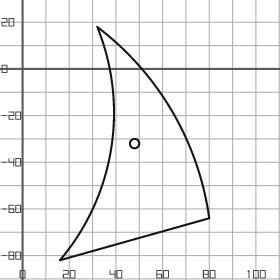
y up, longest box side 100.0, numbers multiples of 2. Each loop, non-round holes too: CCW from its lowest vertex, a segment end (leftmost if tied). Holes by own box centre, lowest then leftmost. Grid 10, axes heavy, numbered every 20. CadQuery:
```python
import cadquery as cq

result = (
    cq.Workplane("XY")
    .moveTo(16.0, -82.0)
    .lineTo(80.0, -64.0)
    .threePointArc((64.0, -18.0), (32.0, 18.0))
    .threePointArc((38.0, -34.0), (16.0, -82.0))
    .close()
    .moveTo(48.0, -32.0)
    .circle(2.0)
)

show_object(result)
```